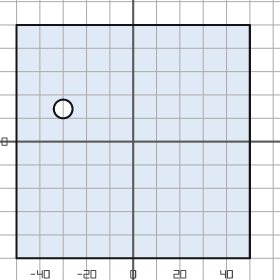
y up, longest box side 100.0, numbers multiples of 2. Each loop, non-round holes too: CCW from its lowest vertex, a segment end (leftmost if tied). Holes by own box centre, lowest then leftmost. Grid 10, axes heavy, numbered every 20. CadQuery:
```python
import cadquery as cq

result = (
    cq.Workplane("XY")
    .moveTo(-50.0, -50.0)
    .lineTo(50.0, -50.0)
    .lineTo(50.0, 50.0)
    .lineTo(-50.0, 50.0)
    .close()
    .moveTo(-30.0, 14.0)
    .circle(4.0)
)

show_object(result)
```